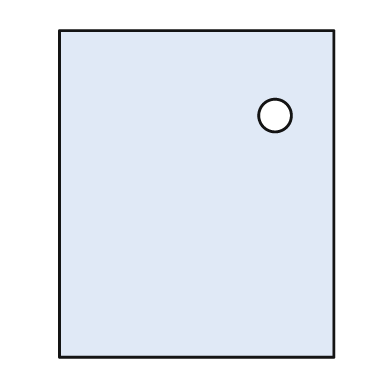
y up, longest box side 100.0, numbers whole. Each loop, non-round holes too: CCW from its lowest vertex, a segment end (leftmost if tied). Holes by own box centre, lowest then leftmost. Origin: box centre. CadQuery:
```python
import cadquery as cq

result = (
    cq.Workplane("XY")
    .moveTo(-42.0, -50.0)
    .lineTo(42.0, -50.0)
    .lineTo(42.0, 50.0)
    .lineTo(-42.0, 50.0)
    .close()
    .moveTo(24.0, 24.0)
    .circle(5.0)
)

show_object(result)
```